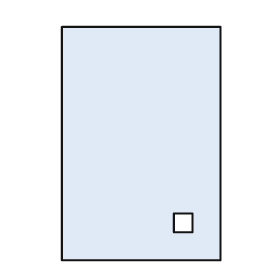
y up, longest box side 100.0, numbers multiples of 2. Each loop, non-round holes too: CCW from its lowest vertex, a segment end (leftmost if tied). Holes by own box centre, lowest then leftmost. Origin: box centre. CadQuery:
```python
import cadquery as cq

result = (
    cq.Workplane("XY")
    .moveTo(-34.0, -50.0)
    .lineTo(34.0, -50.0)
    .lineTo(34.0, 50.0)
    .lineTo(-34.0, 50.0)
    .close()
    .moveTo(14.0, -38.0)
    .lineTo(22.0, -38.0)
    .lineTo(22.0, -30.0)
    .lineTo(14.0, -30.0)
    .close()
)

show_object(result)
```